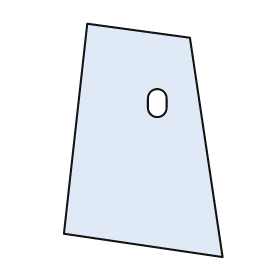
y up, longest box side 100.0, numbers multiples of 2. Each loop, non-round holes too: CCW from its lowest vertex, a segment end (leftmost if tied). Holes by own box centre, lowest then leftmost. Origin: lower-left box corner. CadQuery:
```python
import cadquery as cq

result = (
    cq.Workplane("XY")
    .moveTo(68.0, 0.0)
    .lineTo(54.0, 94.0)
    .lineTo(10.0, 100.0)
    .lineTo(0.0, 10.0)
    .close()
    .moveTo(36.0, 64.0)
    .threePointArc((40.0, 60.0), (44.0, 64.0))
    .lineTo(44.0, 68.0)
    .threePointArc((40.0, 72.0), (36.0, 68.0))
    .close()
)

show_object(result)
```